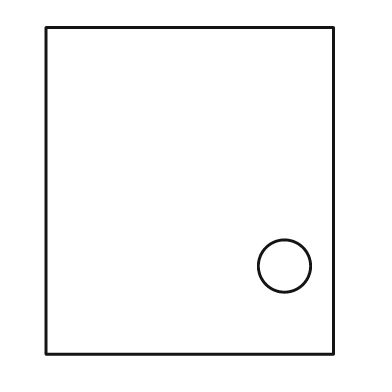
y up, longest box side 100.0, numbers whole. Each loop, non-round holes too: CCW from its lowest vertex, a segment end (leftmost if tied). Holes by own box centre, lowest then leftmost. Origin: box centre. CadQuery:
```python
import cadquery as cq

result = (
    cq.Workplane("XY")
    .moveTo(-44.0, -50.0)
    .lineTo(44.0, -50.0)
    .lineTo(44.0, 50.0)
    .lineTo(-44.0, 50.0)
    .close()
    .moveTo(29.0, -23.0)
    .circle(8.0)
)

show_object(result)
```